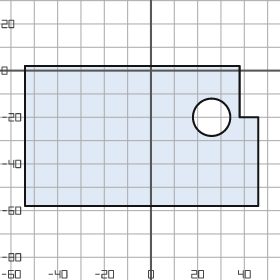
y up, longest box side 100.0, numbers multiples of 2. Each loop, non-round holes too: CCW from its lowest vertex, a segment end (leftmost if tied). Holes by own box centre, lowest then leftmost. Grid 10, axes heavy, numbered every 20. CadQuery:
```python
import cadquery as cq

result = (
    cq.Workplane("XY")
    .moveTo(-54.0, -58.0)
    .lineTo(46.0, -58.0)
    .lineTo(46.0, -20.0)
    .lineTo(38.0, -20.0)
    .lineTo(38.0, 2.0)
    .lineTo(-54.0, 2.0)
    .close()
    .moveTo(26.0, -20.0)
    .circle(8.0)
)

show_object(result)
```